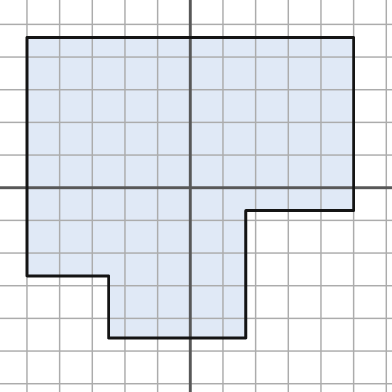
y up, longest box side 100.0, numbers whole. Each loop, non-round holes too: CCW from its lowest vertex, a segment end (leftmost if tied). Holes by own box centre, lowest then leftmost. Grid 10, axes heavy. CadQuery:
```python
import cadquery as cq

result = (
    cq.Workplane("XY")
    .moveTo(-25.0, -46.0)
    .lineTo(17.0, -46.0)
    .lineTo(17.0, -7.0)
    .lineTo(50.0, -7.0)
    .lineTo(50.0, 46.0)
    .lineTo(-50.0, 46.0)
    .lineTo(-50.0, -27.0)
    .lineTo(-25.0, -27.0)
    .close()
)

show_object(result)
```